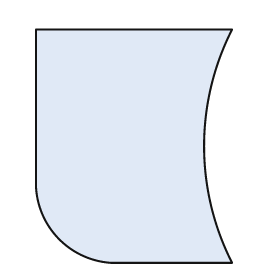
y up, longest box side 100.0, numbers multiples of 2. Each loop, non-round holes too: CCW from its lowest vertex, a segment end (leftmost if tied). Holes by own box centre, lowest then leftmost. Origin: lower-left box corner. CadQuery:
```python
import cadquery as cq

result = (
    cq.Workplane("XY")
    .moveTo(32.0, 0.0)
    .lineTo(84.0, 0.0)
    .threePointArc((72.0, 50.0), (84.0, 100.0))
    .lineTo(0.0, 100.0)
    .lineTo(0.0, 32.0)
    .threePointArc((10.0, 10.0), (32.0, 0.0))
    .close()
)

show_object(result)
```